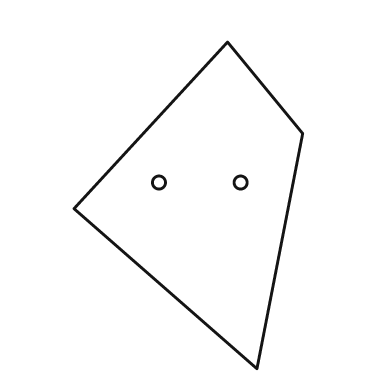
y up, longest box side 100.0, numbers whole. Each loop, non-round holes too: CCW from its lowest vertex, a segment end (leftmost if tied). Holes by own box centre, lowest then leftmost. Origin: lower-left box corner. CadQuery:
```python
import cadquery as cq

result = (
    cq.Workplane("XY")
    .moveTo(56.0, 0.0)
    .lineTo(70.0, 72.0)
    .lineTo(47.0, 100.0)
    .lineTo(0.0, 49.0)
    .close()
    .moveTo(26.0, 57.0)
    .circle(2.0)
    .moveTo(51.0, 57.0)
    .circle(2.0)
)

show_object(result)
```